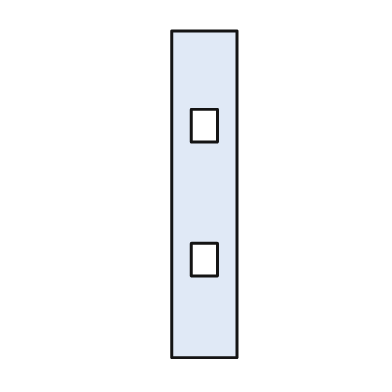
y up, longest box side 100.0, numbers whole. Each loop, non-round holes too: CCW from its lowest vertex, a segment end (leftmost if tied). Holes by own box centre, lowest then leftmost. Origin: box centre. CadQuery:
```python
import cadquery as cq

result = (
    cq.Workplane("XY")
    .moveTo(-10.0, -50.0)
    .lineTo(10.0, -50.0)
    .lineTo(10.0, 50.0)
    .lineTo(-10.0, 50.0)
    .close()
    .moveTo(-4.0, -25.0)
    .lineTo(4.0, -25.0)
    .lineTo(4.0, -15.0)
    .lineTo(-4.0, -15.0)
    .close()
    .moveTo(-4.0, 16.0)
    .lineTo(4.0, 16.0)
    .lineTo(4.0, 26.0)
    .lineTo(-4.0, 26.0)
    .close()
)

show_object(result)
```